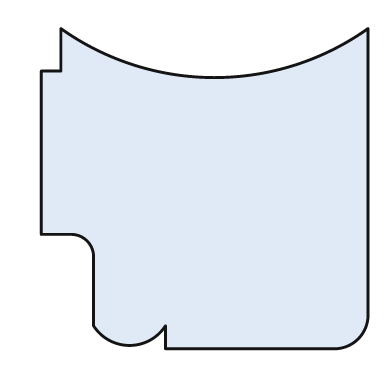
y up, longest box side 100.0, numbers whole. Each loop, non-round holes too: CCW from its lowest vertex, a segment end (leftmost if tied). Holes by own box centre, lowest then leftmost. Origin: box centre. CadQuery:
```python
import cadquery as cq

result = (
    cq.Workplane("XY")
    .moveTo(-12.0, -49.0)
    .lineTo(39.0, -49.0)
    .threePointArc((47.0, -46.0), (50.0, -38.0))
    .lineTo(50.0, 49.0)
    .threePointArc((3.0, 34.0), (-44.0, 49.0))
    .lineTo(-44.0, 36.0)
    .lineTo(-50.0, 36.0)
    .lineTo(-50.0, -14.0)
    .lineTo(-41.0, -14.0)
    .threePointArc((-36.0, -16.0), (-34.0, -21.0))
    .lineTo(-34.0, -42.0)
    .threePointArc((-23.0, -48.0), (-12.0, -42.0))
    .close()
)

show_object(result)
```